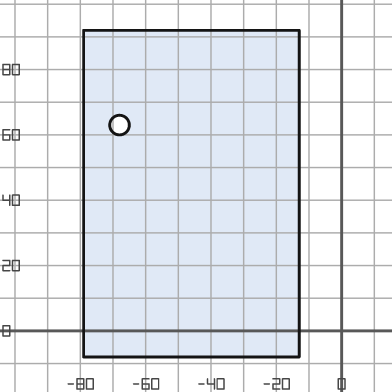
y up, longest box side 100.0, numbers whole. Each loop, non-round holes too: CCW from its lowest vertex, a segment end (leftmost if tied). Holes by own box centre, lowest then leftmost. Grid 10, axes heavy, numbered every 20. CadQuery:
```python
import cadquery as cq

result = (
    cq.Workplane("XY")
    .moveTo(-79.0, -8.0)
    .lineTo(-13.0, -8.0)
    .lineTo(-13.0, 92.0)
    .lineTo(-79.0, 92.0)
    .close()
    .moveTo(-68.0, 63.0)
    .circle(3.0)
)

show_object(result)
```